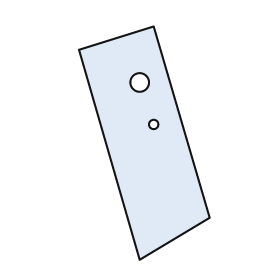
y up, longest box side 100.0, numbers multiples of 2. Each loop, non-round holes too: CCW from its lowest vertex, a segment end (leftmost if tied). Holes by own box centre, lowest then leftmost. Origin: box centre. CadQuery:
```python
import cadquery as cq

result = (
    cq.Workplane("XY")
    .moveTo(-2.0, -50.0)
    .lineTo(28.0, -32.0)
    .lineTo(4.0, 50.0)
    .lineTo(-28.0, 40.0)
    .close()
    .moveTo(4.0, 8.0)
    .circle(2.0)
    .moveTo(-2.0, 26.0)
    .circle(4.0)
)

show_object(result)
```